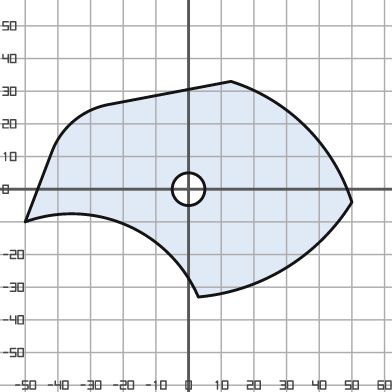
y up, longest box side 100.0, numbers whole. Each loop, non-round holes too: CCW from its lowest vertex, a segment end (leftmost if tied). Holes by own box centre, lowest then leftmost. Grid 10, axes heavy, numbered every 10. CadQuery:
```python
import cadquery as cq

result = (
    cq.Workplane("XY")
    .moveTo(3.0, -33.0)
    .threePointArc((30.0, -24.0), (50.0, -4.0))
    .threePointArc((36.0, 19.0), (13.0, 33.0))
    .lineTo(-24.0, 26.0)
    .threePointArc((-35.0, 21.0), (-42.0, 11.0))
    .lineTo(-50.0, -10.0)
    .threePointArc((-19.0, -11.0), (3.0, -33.0))
    .close()
    .moveTo(0.0, 0.0)
    .circle(5.0)
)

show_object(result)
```